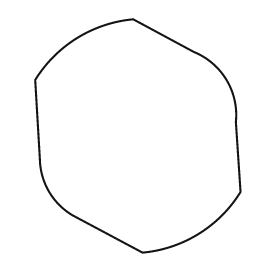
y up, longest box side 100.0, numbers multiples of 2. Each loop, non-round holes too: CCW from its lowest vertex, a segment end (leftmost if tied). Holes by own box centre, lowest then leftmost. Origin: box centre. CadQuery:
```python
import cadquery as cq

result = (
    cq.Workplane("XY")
    .moveTo(2.0, -50.0)
    .threePointArc((26.0, -42.0), (44.0, -24.0))
    .lineTo(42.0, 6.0)
    .threePointArc((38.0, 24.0), (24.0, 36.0))
    .lineTo(-2.0, 50.0)
    .threePointArc((-26.0, 42.0), (-44.0, 24.0))
    .lineTo(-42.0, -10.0)
    .threePointArc((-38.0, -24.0), (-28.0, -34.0))
    .close()
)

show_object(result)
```